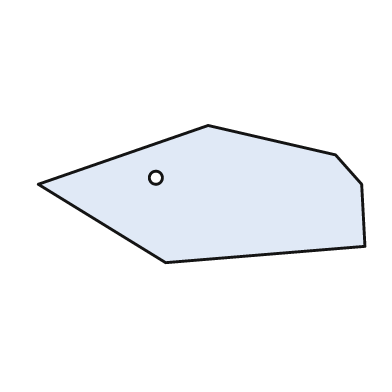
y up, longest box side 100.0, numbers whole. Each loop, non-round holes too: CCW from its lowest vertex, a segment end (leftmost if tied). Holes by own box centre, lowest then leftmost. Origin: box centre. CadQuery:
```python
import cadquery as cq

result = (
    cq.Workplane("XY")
    .moveTo(-11.0, -21.0)
    .lineTo(50.0, -16.0)
    .lineTo(49.0, 3.0)
    .lineTo(41.0, 12.0)
    .lineTo(2.0, 21.0)
    .lineTo(-50.0, 3.0)
    .close()
    .moveTo(-14.0, 5.0)
    .circle(2.0)
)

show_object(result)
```